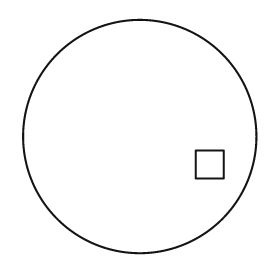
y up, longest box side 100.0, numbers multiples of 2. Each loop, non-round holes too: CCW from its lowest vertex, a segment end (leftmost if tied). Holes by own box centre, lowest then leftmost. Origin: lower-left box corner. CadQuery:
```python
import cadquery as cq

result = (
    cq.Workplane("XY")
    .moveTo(50.0, 50.0)
    .circle(50.0)
    .moveTo(74.0, 32.0)
    .lineTo(86.0, 32.0)
    .lineTo(86.0, 44.0)
    .lineTo(74.0, 44.0)
    .close()
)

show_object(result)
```